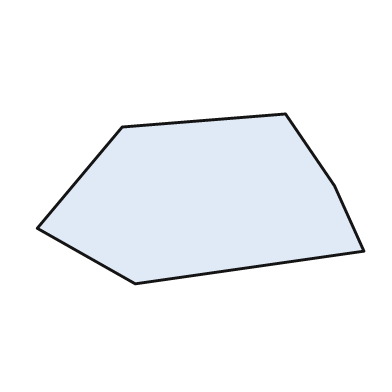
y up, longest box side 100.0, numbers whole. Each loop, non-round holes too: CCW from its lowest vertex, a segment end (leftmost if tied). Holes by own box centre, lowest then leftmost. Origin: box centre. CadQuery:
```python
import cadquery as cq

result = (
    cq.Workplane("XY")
    .moveTo(-20.0, -26.0)
    .lineTo(50.0, -16.0)
    .lineTo(41.0, 4.0)
    .lineTo(26.0, 26.0)
    .lineTo(-24.0, 22.0)
    .lineTo(-50.0, -9.0)
    .close()
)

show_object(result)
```